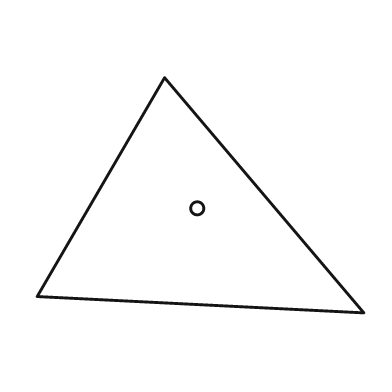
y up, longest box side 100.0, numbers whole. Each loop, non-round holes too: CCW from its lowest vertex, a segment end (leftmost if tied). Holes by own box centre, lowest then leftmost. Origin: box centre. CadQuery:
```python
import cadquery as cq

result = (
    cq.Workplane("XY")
    .moveTo(50.0, -36.0)
    .lineTo(-11.0, 36.0)
    .lineTo(-50.0, -31.0)
    .close()
    .moveTo(-1.0, -4.0)
    .circle(2.0)
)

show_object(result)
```